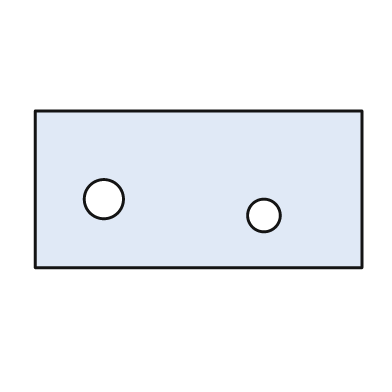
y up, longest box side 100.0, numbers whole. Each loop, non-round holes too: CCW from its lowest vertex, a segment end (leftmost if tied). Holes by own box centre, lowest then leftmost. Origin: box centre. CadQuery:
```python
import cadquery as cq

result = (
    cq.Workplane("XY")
    .moveTo(-50.0, -24.0)
    .lineTo(50.0, -24.0)
    .lineTo(50.0, 24.0)
    .lineTo(-50.0, 24.0)
    .close()
    .moveTo(20.0, -8.0)
    .circle(5.0)
    .moveTo(-29.0, -3.0)
    .circle(6.0)
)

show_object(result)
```